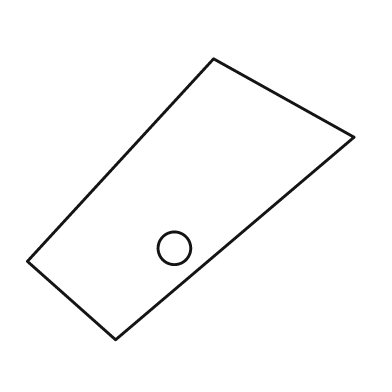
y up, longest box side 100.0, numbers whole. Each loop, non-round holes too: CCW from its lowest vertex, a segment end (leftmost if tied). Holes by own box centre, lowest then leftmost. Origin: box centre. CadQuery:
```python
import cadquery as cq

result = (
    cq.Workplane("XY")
    .moveTo(-23.0, -43.0)
    .lineTo(50.0, 19.0)
    .lineTo(7.0, 43.0)
    .lineTo(-50.0, -19.0)
    .close()
    .moveTo(-5.0, -15.0)
    .circle(5.0)
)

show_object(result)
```